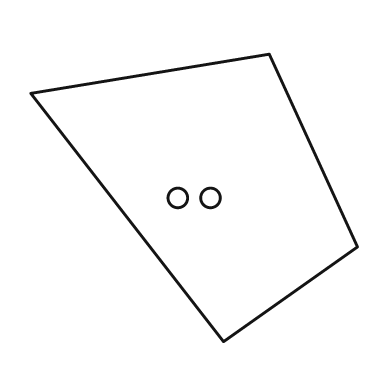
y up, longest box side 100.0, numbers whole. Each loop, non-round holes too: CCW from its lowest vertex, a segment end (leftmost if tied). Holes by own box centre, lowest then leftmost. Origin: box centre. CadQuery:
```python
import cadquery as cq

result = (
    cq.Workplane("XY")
    .moveTo(9.0, -44.0)
    .lineTo(50.0, -15.0)
    .lineTo(23.0, 44.0)
    .lineTo(-50.0, 32.0)
    .close()
    .moveTo(-5.0, 0.0)
    .circle(3.0)
    .moveTo(5.0, 0.0)
    .circle(3.0)
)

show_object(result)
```